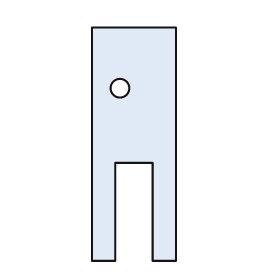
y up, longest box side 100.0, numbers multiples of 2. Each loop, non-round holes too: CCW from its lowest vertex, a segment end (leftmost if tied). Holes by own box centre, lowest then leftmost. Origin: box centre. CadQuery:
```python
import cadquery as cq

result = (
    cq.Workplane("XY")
    .moveTo(-18.0, -50.0)
    .lineTo(-8.0, -50.0)
    .lineTo(-8.0, -8.0)
    .lineTo(8.0, -8.0)
    .lineTo(8.0, -50.0)
    .lineTo(18.0, -50.0)
    .lineTo(18.0, 50.0)
    .lineTo(-18.0, 50.0)
    .close()
    .moveTo(-6.0, 24.0)
    .circle(4.0)
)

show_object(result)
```